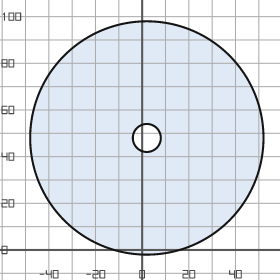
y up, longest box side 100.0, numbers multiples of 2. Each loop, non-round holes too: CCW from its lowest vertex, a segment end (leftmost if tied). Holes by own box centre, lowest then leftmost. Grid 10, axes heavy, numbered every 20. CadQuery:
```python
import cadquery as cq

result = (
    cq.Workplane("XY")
    .moveTo(2.0, 48.0)
    .circle(50.0)
    .moveTo(2.0, 48.0)
    .circle(6.0)
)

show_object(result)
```